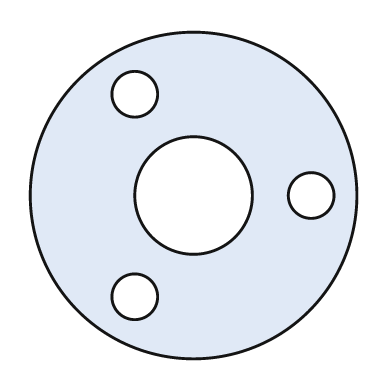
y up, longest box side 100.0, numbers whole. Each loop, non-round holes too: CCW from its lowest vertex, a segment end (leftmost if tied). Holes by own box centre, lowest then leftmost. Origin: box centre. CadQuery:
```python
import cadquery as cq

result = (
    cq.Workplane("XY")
    .moveTo(0.0, 0.0)
    .circle(50.0)
    .moveTo(-18.0, -31.0)
    .circle(7.0)
    .moveTo(0.0, 0.0)
    .circle(18.0)
    .moveTo(36.0, 0.0)
    .circle(7.0)
    .moveTo(-18.0, 31.0)
    .circle(7.0)
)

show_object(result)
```